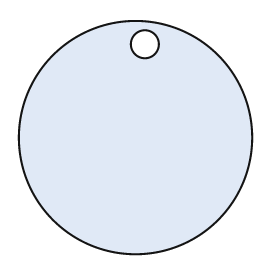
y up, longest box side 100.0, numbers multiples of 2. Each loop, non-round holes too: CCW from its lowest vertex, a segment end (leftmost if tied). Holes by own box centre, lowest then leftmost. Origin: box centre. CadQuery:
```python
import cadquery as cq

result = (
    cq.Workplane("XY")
    .moveTo(0.0, 0.0)
    .circle(50.0)
    .moveTo(4.0, 40.0)
    .circle(6.0)
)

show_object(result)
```